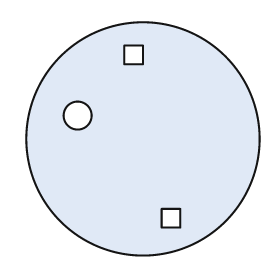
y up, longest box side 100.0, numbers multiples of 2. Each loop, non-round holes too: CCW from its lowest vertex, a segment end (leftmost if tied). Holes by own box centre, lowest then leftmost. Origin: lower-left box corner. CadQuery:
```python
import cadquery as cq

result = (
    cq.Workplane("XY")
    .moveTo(50.0, 50.0)
    .circle(50.0)
    .moveTo(58.0, 12.0)
    .lineTo(66.0, 12.0)
    .lineTo(66.0, 20.0)
    .lineTo(58.0, 20.0)
    .close()
    .moveTo(22.0, 60.0)
    .circle(6.0)
    .moveTo(42.0, 82.0)
    .lineTo(50.0, 82.0)
    .lineTo(50.0, 90.0)
    .lineTo(42.0, 90.0)
    .close()
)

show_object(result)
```